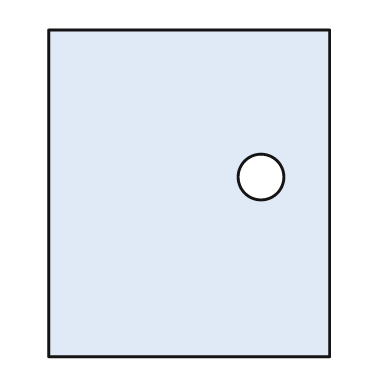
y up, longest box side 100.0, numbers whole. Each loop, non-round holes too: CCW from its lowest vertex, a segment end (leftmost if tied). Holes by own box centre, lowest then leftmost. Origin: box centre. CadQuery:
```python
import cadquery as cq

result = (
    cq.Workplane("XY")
    .moveTo(-43.0, -50.0)
    .lineTo(43.0, -50.0)
    .lineTo(43.0, 50.0)
    .lineTo(-43.0, 50.0)
    .close()
    .moveTo(22.0, 5.0)
    .circle(7.0)
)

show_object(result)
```